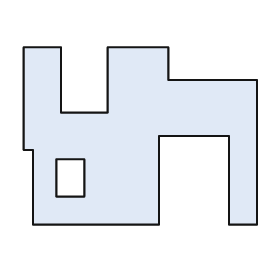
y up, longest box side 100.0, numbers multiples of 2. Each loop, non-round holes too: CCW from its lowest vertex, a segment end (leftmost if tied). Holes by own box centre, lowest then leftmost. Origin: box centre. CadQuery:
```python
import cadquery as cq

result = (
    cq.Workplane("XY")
    .moveTo(-46.0, -38.0)
    .lineTo(8.0, -38.0)
    .lineTo(8.0, 0.0)
    .lineTo(38.0, 0.0)
    .lineTo(38.0, -38.0)
    .lineTo(50.0, -38.0)
    .lineTo(50.0, 24.0)
    .lineTo(12.0, 24.0)
    .lineTo(12.0, 38.0)
    .lineTo(-14.0, 38.0)
    .lineTo(-14.0, 10.0)
    .lineTo(-34.0, 10.0)
    .lineTo(-34.0, 38.0)
    .lineTo(-50.0, 38.0)
    .lineTo(-50.0, -6.0)
    .lineTo(-46.0, -6.0)
    .close()
    .moveTo(-36.0, -26.0)
    .lineTo(-24.0, -26.0)
    .lineTo(-24.0, -10.0)
    .lineTo(-36.0, -10.0)
    .close()
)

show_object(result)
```